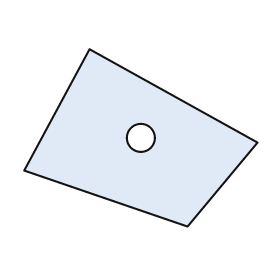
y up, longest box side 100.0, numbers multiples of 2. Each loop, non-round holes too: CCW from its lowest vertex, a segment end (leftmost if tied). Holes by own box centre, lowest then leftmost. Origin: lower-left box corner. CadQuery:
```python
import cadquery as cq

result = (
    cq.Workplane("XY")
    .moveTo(70.0, 0.0)
    .lineTo(100.0, 36.0)
    .lineTo(28.0, 76.0)
    .lineTo(0.0, 24.0)
    .close()
    .moveTo(50.0, 38.0)
    .circle(6.0)
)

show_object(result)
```